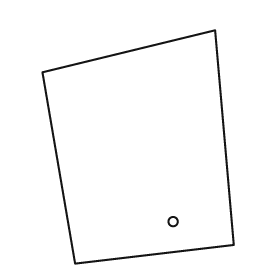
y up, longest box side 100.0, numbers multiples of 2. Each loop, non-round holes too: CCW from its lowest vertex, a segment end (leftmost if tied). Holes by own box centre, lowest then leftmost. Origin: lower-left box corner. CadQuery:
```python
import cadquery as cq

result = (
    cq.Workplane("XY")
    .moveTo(14.0, 0.0)
    .lineTo(82.0, 8.0)
    .lineTo(74.0, 100.0)
    .lineTo(0.0, 82.0)
    .close()
    .moveTo(56.0, 18.0)
    .circle(2.0)
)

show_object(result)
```